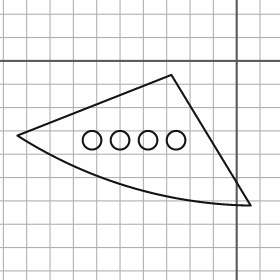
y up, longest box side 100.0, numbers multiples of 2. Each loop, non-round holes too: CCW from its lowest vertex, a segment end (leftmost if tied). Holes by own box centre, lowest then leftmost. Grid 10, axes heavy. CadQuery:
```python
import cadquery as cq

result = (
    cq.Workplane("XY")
    .moveTo(6.0, -62.0)
    .lineTo(-28.0, -6.0)
    .lineTo(-94.0, -32.0)
    .threePointArc((-46.0, -54.0), (6.0, -62.0))
    .close()
    .moveTo(-62.0, -34.0)
    .circle(4.0)
    .moveTo(-50.0, -34.0)
    .circle(4.0)
    .moveTo(-38.0, -34.0)
    .circle(4.0)
    .moveTo(-26.0, -34.0)
    .circle(4.0)
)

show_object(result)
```